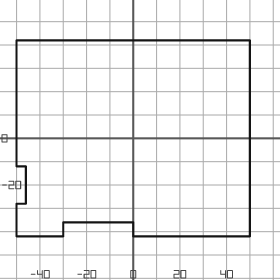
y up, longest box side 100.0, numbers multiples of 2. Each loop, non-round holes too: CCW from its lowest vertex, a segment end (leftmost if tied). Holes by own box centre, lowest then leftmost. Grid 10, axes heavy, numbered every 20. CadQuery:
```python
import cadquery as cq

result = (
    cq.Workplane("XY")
    .moveTo(-50.0, -42.0)
    .lineTo(-30.0, -42.0)
    .lineTo(-30.0, -36.0)
    .lineTo(0.0, -36.0)
    .lineTo(0.0, -42.0)
    .lineTo(50.0, -42.0)
    .lineTo(50.0, 42.0)
    .lineTo(-50.0, 42.0)
    .lineTo(-50.0, -12.0)
    .lineTo(-46.0, -12.0)
    .lineTo(-46.0, -28.0)
    .lineTo(-50.0, -28.0)
    .close()
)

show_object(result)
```